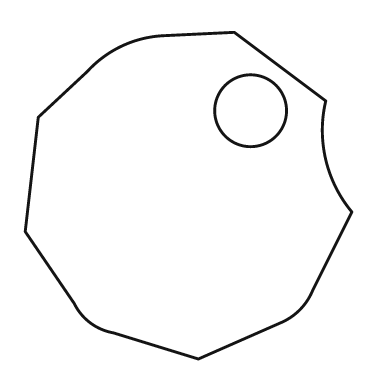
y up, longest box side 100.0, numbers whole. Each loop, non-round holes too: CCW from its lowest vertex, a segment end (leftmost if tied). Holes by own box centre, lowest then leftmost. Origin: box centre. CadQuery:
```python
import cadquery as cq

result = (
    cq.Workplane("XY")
    .moveTo(3.0, -50.0)
    .lineTo(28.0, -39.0)
    .threePointArc((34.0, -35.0), (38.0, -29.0))
    .lineTo(50.0, -5.0)
    .threePointArc((42.0, 11.0), (42.0, 29.0))
    .lineTo(14.0, 50.0)
    .lineTo(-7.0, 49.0)
    .threePointArc((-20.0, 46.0), (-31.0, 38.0))
    .lineTo(-46.0, 24.0)
    .lineTo(-50.0, -11.0)
    .lineTo(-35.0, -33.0)
    .threePointArc((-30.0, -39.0), (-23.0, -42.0))
    .close()
    .moveTo(19.0, 26.0)
    .circle(11.0)
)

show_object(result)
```